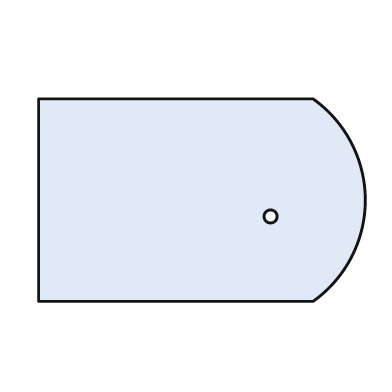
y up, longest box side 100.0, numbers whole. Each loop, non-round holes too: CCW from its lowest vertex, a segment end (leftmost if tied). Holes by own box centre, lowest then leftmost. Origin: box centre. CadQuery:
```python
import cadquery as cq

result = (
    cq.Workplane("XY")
    .moveTo(-50.0, -31.0)
    .lineTo(34.0, -31.0)
    .threePointArc((50.0, 0.0), (34.0, 31.0))
    .lineTo(-50.0, 31.0)
    .close()
    .moveTo(21.0, -5.0)
    .circle(2.0)
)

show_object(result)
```